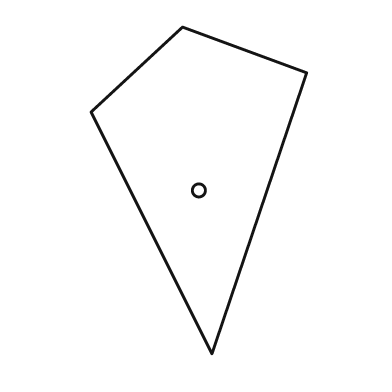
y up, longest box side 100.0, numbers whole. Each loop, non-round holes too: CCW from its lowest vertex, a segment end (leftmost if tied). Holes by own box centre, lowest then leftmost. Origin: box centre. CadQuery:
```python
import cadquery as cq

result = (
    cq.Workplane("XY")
    .moveTo(4.0, -50.0)
    .lineTo(33.0, 36.0)
    .lineTo(-5.0, 50.0)
    .lineTo(-33.0, 24.0)
    .close()
    .moveTo(0.0, 0.0)
    .circle(2.0)
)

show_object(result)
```